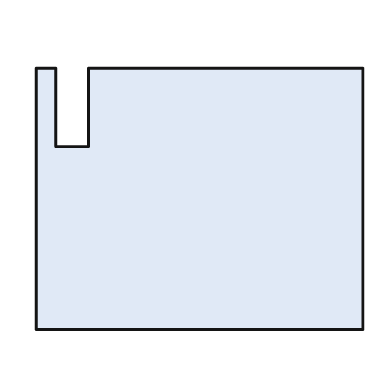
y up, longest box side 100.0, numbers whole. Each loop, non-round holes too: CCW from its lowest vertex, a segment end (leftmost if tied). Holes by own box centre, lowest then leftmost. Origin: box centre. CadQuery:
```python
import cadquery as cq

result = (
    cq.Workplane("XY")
    .moveTo(-50.0, -40.0)
    .lineTo(50.0, -40.0)
    .lineTo(50.0, 40.0)
    .lineTo(-34.0, 40.0)
    .lineTo(-34.0, 16.0)
    .lineTo(-44.0, 16.0)
    .lineTo(-44.0, 40.0)
    .lineTo(-50.0, 40.0)
    .close()
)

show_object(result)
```